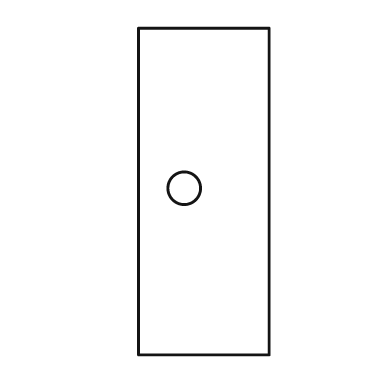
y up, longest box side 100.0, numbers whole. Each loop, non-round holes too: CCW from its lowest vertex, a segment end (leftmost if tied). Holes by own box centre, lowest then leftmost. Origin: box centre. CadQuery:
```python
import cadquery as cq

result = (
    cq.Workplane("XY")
    .moveTo(-20.0, -50.0)
    .lineTo(20.0, -50.0)
    .lineTo(20.0, 50.0)
    .lineTo(-20.0, 50.0)
    .close()
    .moveTo(-6.0, 1.0)
    .circle(5.0)
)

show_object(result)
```